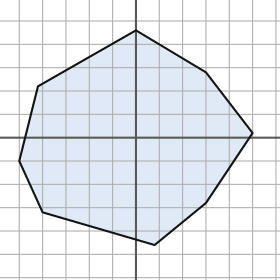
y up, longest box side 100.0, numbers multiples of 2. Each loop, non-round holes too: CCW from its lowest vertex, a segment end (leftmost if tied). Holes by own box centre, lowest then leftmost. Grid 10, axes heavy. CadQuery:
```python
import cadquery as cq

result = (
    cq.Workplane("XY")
    .moveTo(8.0, -46.0)
    .lineTo(30.0, -28.0)
    .lineTo(50.0, 2.0)
    .lineTo(30.0, 28.0)
    .lineTo(0.0, 46.0)
    .lineTo(-42.0, 22.0)
    .lineTo(-50.0, -10.0)
    .lineTo(-40.0, -32.0)
    .close()
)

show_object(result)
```